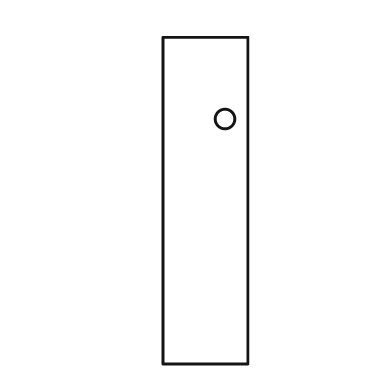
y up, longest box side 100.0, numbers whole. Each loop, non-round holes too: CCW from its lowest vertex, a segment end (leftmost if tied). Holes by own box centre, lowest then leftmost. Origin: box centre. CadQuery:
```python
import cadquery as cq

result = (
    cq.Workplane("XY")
    .moveTo(-13.0, -50.0)
    .lineTo(13.0, -50.0)
    .lineTo(13.0, 50.0)
    .lineTo(-13.0, 50.0)
    .close()
    .moveTo(6.0, 25.0)
    .circle(3.0)
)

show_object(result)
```